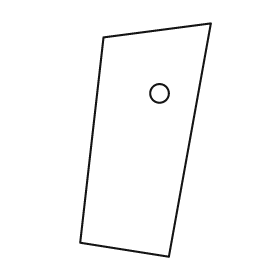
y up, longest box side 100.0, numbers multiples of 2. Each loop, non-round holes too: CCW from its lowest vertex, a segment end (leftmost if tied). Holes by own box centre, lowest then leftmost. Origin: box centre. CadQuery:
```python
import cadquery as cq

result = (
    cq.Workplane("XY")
    .moveTo(10.0, -50.0)
    .lineTo(28.0, 50.0)
    .lineTo(-18.0, 44.0)
    .lineTo(-28.0, -44.0)
    .close()
    .moveTo(6.0, 20.0)
    .circle(4.0)
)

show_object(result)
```